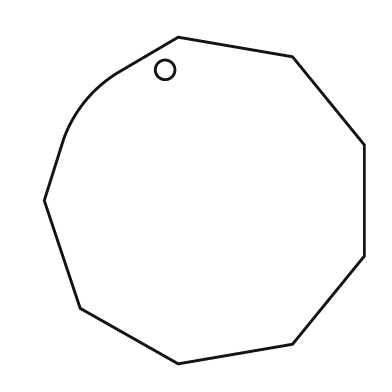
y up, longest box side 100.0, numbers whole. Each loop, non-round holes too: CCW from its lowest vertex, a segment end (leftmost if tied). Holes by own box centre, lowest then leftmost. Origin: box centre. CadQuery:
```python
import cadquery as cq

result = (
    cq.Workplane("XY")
    .moveTo(-8.0, -50.0)
    .lineTo(27.0, -44.0)
    .lineTo(49.0, -17.0)
    .lineTo(49.0, 17.0)
    .lineTo(27.0, 44.0)
    .lineTo(-8.0, 50.0)
    .lineTo(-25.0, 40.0)
    .threePointArc((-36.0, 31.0), (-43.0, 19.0))
    .lineTo(-49.0, 0.0)
    .lineTo(-38.0, -33.0)
    .close()
    .moveTo(-12.0, 40.0)
    .circle(3.0)
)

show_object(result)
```